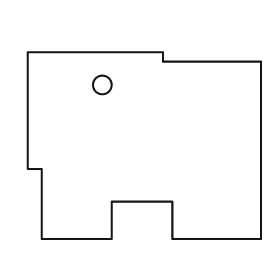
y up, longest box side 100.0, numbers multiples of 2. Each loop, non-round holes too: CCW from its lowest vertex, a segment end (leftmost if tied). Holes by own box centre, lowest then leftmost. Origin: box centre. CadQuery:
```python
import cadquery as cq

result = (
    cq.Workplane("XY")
    .moveTo(-44.0, -40.0)
    .lineTo(-14.0, -40.0)
    .lineTo(-14.0, -24.0)
    .lineTo(12.0, -24.0)
    .lineTo(12.0, -40.0)
    .lineTo(50.0, -40.0)
    .lineTo(50.0, 36.0)
    .lineTo(8.0, 36.0)
    .lineTo(8.0, 40.0)
    .lineTo(-50.0, 40.0)
    .lineTo(-50.0, -10.0)
    .lineTo(-44.0, -10.0)
    .close()
    .moveTo(-18.0, 26.0)
    .circle(4.0)
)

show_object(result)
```